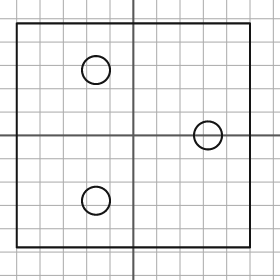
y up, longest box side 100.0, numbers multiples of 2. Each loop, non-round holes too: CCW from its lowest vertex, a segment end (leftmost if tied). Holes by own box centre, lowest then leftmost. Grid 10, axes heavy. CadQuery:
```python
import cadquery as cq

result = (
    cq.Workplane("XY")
    .moveTo(-50.0, -48.0)
    .lineTo(50.0, -48.0)
    .lineTo(50.0, 48.0)
    .lineTo(-50.0, 48.0)
    .close()
    .moveTo(-16.0, -28.0)
    .circle(6.0)
    .moveTo(32.0, 0.0)
    .circle(6.0)
    .moveTo(-16.0, 28.0)
    .circle(6.0)
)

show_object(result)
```